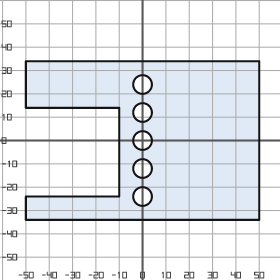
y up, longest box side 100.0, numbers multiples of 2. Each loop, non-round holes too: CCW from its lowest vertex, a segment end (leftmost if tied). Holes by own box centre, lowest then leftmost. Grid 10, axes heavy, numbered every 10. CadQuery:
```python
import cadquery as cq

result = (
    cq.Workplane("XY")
    .moveTo(-50.0, -34.0)
    .lineTo(50.0, -34.0)
    .lineTo(50.0, 34.0)
    .lineTo(-50.0, 34.0)
    .lineTo(-50.0, 14.0)
    .lineTo(-10.0, 14.0)
    .lineTo(-10.0, -24.0)
    .lineTo(-50.0, -24.0)
    .close()
    .moveTo(0.0, -24.0)
    .circle(4.0)
    .moveTo(0.0, -12.0)
    .circle(4.0)
    .moveTo(0.0, 0.0)
    .circle(4.0)
    .moveTo(0.0, 12.0)
    .circle(4.0)
    .moveTo(0.0, 24.0)
    .circle(4.0)
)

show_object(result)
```